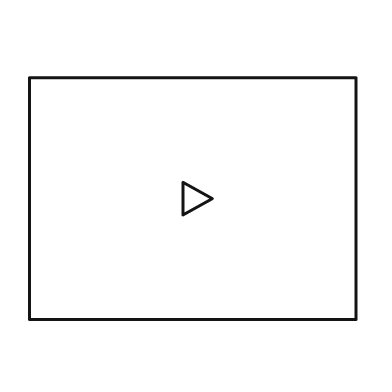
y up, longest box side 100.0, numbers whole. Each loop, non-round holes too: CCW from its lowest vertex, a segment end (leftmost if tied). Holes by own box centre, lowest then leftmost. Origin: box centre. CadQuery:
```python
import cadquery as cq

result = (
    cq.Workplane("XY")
    .moveTo(-50.0, -37.0)
    .lineTo(50.0, -37.0)
    .lineTo(50.0, 37.0)
    .lineTo(-50.0, 37.0)
    .close()
    .moveTo(-3.0, -5.0)
    .lineTo(6.0, 0.0)
    .lineTo(-3.0, 5.0)
    .close()
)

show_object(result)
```